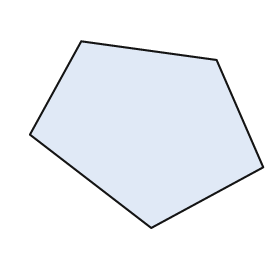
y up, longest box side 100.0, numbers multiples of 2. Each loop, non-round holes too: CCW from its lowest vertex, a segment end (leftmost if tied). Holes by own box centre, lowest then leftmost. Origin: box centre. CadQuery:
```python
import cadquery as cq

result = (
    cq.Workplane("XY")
    .moveTo(2.0, -40.0)
    .lineTo(50.0, -14.0)
    .lineTo(30.0, 32.0)
    .lineTo(-28.0, 40.0)
    .lineTo(-50.0, 0.0)
    .close()
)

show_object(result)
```